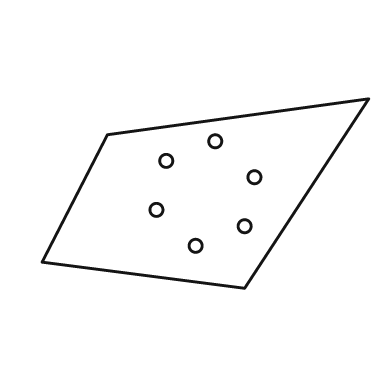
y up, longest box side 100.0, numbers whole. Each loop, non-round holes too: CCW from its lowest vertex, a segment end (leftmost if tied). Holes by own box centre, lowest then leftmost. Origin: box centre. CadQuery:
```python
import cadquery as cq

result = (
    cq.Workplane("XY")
    .moveTo(12.0, -29.0)
    .lineTo(50.0, 29.0)
    .lineTo(-30.0, 18.0)
    .lineTo(-50.0, -21.0)
    .close()
    .moveTo(-3.0, -16.0)
    .circle(2.0)
    .moveTo(12.0, -10.0)
    .circle(2.0)
    .moveTo(-15.0, -5.0)
    .circle(2.0)
    .moveTo(15.0, 5.0)
    .circle(2.0)
    .moveTo(-12.0, 10.0)
    .circle(2.0)
    .moveTo(3.0, 16.0)
    .circle(2.0)
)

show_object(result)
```